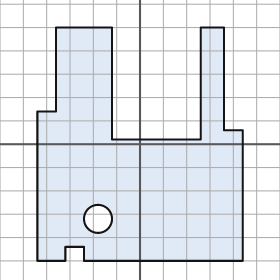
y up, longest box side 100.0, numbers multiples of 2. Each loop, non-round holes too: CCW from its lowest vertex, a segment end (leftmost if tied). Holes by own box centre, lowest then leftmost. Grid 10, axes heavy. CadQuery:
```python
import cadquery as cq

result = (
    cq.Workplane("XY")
    .moveTo(-44.0, -50.0)
    .lineTo(-32.0, -50.0)
    .lineTo(-32.0, -44.0)
    .lineTo(-24.0, -44.0)
    .lineTo(-24.0, -50.0)
    .lineTo(44.0, -50.0)
    .lineTo(44.0, 6.0)
    .lineTo(36.0, 6.0)
    .lineTo(36.0, 50.0)
    .lineTo(26.0, 50.0)
    .lineTo(26.0, 2.0)
    .lineTo(-12.0, 2.0)
    .lineTo(-12.0, 50.0)
    .lineTo(-36.0, 50.0)
    .lineTo(-36.0, 14.0)
    .lineTo(-44.0, 14.0)
    .close()
    .moveTo(-18.0, -32.0)
    .circle(6.0)
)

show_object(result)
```